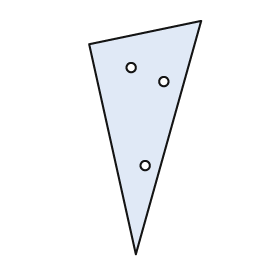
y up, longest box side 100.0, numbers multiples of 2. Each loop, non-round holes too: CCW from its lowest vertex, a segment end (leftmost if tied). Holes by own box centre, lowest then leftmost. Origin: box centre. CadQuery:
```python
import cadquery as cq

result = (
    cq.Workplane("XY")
    .moveTo(-4.0, -50.0)
    .lineTo(24.0, 50.0)
    .lineTo(-24.0, 40.0)
    .close()
    .moveTo(0.0, -12.0)
    .circle(2.0)
    .moveTo(8.0, 24.0)
    .circle(2.0)
    .moveTo(-6.0, 30.0)
    .circle(2.0)
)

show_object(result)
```